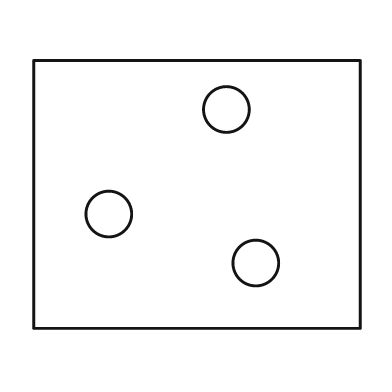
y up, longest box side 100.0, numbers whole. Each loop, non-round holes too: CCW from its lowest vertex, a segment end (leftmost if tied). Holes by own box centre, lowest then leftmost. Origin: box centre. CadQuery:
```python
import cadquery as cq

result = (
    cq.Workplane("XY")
    .moveTo(-50.0, -41.0)
    .lineTo(50.0, -41.0)
    .lineTo(50.0, 41.0)
    .lineTo(-50.0, 41.0)
    .close()
    .moveTo(18.0, -21.0)
    .circle(7.0)
    .moveTo(-27.0, -6.0)
    .circle(7.0)
    .moveTo(9.0, 26.0)
    .circle(7.0)
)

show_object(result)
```